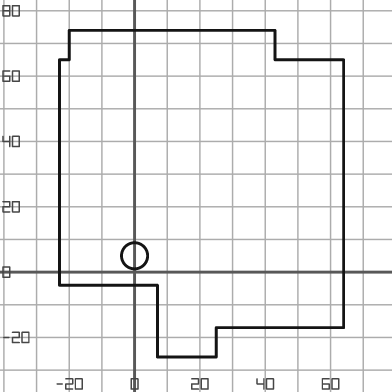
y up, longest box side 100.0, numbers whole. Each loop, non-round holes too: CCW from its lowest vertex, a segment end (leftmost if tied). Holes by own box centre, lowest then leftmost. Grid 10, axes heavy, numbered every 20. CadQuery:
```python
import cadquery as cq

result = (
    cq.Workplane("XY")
    .moveTo(7.0, -26.0)
    .lineTo(25.0, -26.0)
    .lineTo(25.0, -17.0)
    .lineTo(64.0, -17.0)
    .lineTo(64.0, 65.0)
    .lineTo(43.0, 65.0)
    .lineTo(43.0, 74.0)
    .lineTo(-20.0, 74.0)
    .lineTo(-20.0, 65.0)
    .lineTo(-23.0, 65.0)
    .lineTo(-23.0, -4.0)
    .lineTo(7.0, -4.0)
    .close()
    .moveTo(0.0, 5.0)
    .circle(4.0)
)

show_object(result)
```